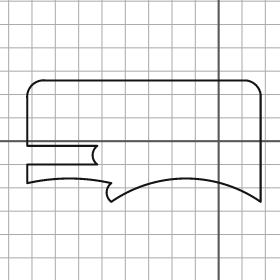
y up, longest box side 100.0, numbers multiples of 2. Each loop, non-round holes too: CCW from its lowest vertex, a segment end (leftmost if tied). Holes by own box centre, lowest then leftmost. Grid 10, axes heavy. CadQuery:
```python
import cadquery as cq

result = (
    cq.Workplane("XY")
    .moveTo(-46.0, -26.0)
    .threePointArc((-14.0, -16.0), (18.0, -26.0))
    .lineTo(18.0, 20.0)
    .threePointArc((16.0, 24.0), (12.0, 26.0))
    .lineTo(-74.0, 26.0)
    .threePointArc((-80.0, 24.0), (-82.0, 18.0))
    .lineTo(-82.0, -2.0)
    .lineTo(-52.0, -2.0)
    .threePointArc((-54.0, -6.0), (-52.0, -10.0))
    .lineTo(-82.0, -10.0)
    .lineTo(-82.0, -18.0)
    .threePointArc((-64.0, -16.0), (-46.0, -18.0))
    .threePointArc((-48.0, -22.0), (-46.0, -26.0))
    .close()
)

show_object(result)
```